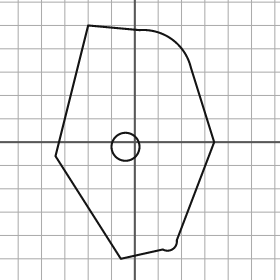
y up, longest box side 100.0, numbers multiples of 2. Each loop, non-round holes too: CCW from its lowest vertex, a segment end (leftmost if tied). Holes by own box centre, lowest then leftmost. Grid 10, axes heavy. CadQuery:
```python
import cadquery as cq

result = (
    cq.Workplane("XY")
    .moveTo(-6.0, -50.0)
    .lineTo(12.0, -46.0)
    .threePointArc((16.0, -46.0), (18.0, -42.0))
    .lineTo(34.0, 0.0)
    .lineTo(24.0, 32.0)
    .threePointArc((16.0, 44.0), (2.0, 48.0))
    .lineTo(-20.0, 50.0)
    .lineTo(-34.0, -6.0)
    .close()
    .moveTo(-4.0, -2.0)
    .circle(6.0)
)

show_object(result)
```